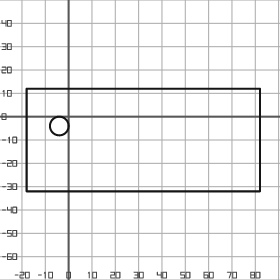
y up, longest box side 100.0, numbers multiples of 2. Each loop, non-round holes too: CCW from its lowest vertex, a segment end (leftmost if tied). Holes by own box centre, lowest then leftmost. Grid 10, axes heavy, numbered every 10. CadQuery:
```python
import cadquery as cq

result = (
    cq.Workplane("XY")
    .moveTo(-18.0, -32.0)
    .lineTo(82.0, -32.0)
    .lineTo(82.0, 12.0)
    .lineTo(-18.0, 12.0)
    .close()
    .moveTo(-4.0, -4.0)
    .circle(4.0)
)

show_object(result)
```